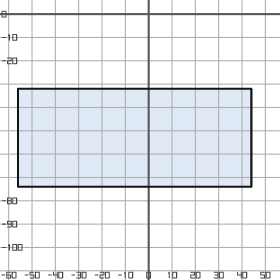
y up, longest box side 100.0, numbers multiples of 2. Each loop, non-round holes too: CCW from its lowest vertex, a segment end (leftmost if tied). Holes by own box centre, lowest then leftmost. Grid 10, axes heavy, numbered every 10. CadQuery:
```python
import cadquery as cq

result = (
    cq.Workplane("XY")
    .moveTo(-56.0, -74.0)
    .lineTo(44.0, -74.0)
    .lineTo(44.0, -32.0)
    .lineTo(-56.0, -32.0)
    .close()
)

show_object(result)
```